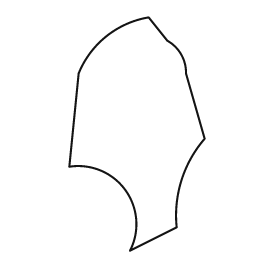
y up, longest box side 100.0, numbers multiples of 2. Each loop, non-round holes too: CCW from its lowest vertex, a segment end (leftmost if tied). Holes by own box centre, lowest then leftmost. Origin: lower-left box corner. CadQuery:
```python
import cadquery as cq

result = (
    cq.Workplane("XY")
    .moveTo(26.0, 0.0)
    .lineTo(46.0, 10.0)
    .threePointArc((48.0, 30.0), (58.0, 48.0))
    .lineTo(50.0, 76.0)
    .threePointArc((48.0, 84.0), (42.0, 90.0))
    .lineTo(34.0, 100.0)
    .threePointArc((16.0, 92.0), (4.0, 76.0))
    .lineTo(0.0, 36.0)
    .threePointArc((24.0, 26.0), (26.0, 0.0))
    .close()
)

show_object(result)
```